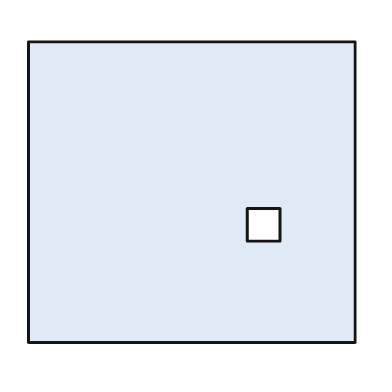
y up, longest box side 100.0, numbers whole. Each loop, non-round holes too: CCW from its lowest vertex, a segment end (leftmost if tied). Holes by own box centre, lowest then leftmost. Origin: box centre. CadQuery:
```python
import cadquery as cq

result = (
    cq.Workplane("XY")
    .moveTo(-50.0, -46.0)
    .lineTo(50.0, -46.0)
    .lineTo(50.0, 46.0)
    .lineTo(-50.0, 46.0)
    .close()
    .moveTo(17.0, -15.0)
    .lineTo(27.0, -15.0)
    .lineTo(27.0, -5.0)
    .lineTo(17.0, -5.0)
    .close()
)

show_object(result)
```